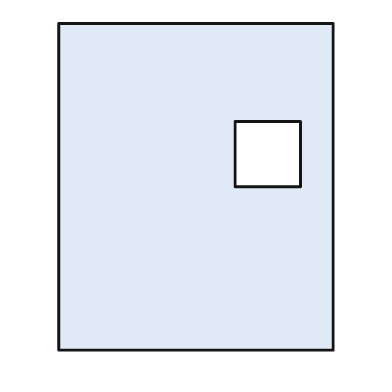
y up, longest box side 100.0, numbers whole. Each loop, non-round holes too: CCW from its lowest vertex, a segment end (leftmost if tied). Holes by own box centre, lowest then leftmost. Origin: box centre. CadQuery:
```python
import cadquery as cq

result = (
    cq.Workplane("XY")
    .moveTo(-42.0, -50.0)
    .lineTo(42.0, -50.0)
    .lineTo(42.0, 50.0)
    .lineTo(-42.0, 50.0)
    .close()
    .moveTo(12.0, 0.0)
    .lineTo(32.0, 0.0)
    .lineTo(32.0, 20.0)
    .lineTo(12.0, 20.0)
    .close()
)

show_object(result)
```